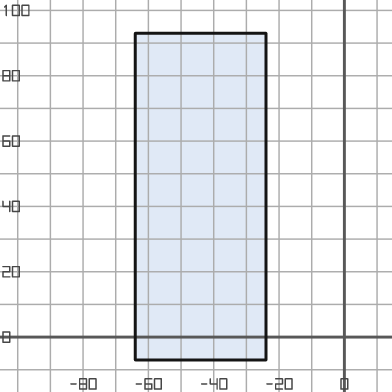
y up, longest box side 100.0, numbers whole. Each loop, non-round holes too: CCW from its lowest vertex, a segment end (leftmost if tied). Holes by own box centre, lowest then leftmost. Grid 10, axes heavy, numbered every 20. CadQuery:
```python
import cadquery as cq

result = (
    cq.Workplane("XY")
    .moveTo(-64.0, -7.0)
    .lineTo(-24.0, -7.0)
    .lineTo(-24.0, 93.0)
    .lineTo(-64.0, 93.0)
    .close()
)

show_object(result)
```